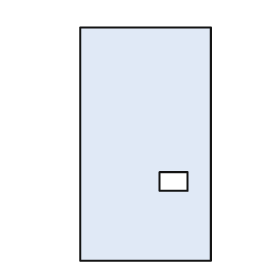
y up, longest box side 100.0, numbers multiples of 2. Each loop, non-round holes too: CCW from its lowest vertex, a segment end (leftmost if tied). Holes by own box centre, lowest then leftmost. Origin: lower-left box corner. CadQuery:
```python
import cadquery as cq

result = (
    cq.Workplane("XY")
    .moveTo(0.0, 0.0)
    .lineTo(56.0, 0.0)
    .lineTo(56.0, 100.0)
    .lineTo(0.0, 100.0)
    .close()
    .moveTo(34.0, 30.0)
    .lineTo(46.0, 30.0)
    .lineTo(46.0, 38.0)
    .lineTo(34.0, 38.0)
    .close()
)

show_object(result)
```